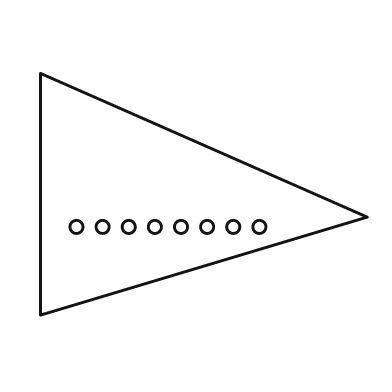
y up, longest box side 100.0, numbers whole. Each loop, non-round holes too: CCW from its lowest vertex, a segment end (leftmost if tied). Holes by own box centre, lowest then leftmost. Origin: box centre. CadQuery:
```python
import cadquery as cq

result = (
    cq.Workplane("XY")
    .moveTo(-50.0, -37.0)
    .lineTo(50.0, -7.0)
    .lineTo(-50.0, 37.0)
    .close()
    .moveTo(-39.0, -10.0)
    .circle(2.0)
    .moveTo(-31.0, -10.0)
    .circle(2.0)
    .moveTo(-23.0, -10.0)
    .circle(2.0)
    .moveTo(-15.0, -10.0)
    .circle(2.0)
    .moveTo(-7.0, -10.0)
    .circle(2.0)
    .moveTo(1.0, -10.0)
    .circle(2.0)
    .moveTo(9.0, -10.0)
    .circle(2.0)
    .moveTo(17.0, -10.0)
    .circle(2.0)
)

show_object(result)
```